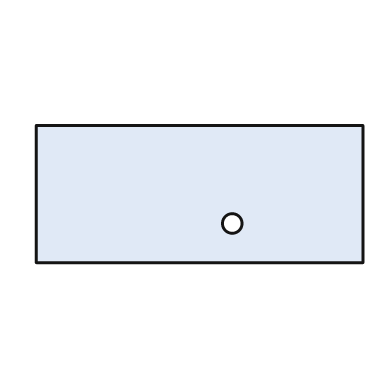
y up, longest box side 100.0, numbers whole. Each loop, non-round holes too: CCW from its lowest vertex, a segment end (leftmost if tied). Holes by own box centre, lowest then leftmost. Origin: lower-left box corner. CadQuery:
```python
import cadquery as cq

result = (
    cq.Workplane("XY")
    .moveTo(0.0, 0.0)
    .lineTo(100.0, 0.0)
    .lineTo(100.0, 42.0)
    .lineTo(0.0, 42.0)
    .close()
    .moveTo(60.0, 12.0)
    .circle(3.0)
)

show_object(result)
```